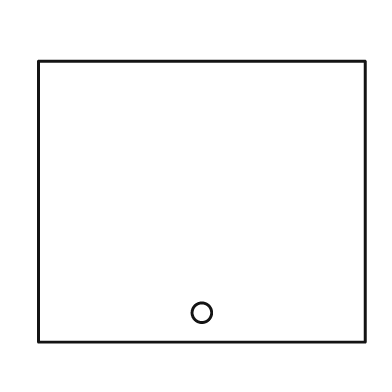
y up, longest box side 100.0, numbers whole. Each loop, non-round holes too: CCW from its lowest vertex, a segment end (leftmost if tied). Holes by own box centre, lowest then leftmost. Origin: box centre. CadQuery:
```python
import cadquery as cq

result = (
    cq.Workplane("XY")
    .moveTo(-50.0, -43.0)
    .lineTo(50.0, -43.0)
    .lineTo(50.0, 43.0)
    .lineTo(-50.0, 43.0)
    .close()
    .moveTo(0.0, -34.0)
    .circle(3.0)
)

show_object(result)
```